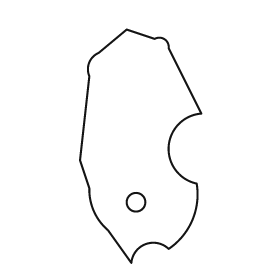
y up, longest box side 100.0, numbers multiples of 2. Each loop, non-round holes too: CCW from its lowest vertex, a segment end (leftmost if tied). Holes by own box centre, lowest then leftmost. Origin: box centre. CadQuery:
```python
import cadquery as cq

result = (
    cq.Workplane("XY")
    .moveTo(-4.0, -50.0)
    .threePointArc((2.0, -42.0), (12.0, -44.0))
    .threePointArc((22.0, -32.0), (24.0, -16.0))
    .threePointArc((12.0, 0.0), (26.0, 14.0))
    .lineTo(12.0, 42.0)
    .threePointArc((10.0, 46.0), (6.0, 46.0))
    .lineTo(-6.0, 50.0)
    .lineTo(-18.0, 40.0)
    .threePointArc((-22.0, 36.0), (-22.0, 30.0))
    .lineTo(-26.0, -6.0)
    .lineTo(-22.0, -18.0)
    .threePointArc((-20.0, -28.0), (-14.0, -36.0))
    .close()
    .moveTo(-2.0, -24.0)
    .circle(4.0)
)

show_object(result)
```